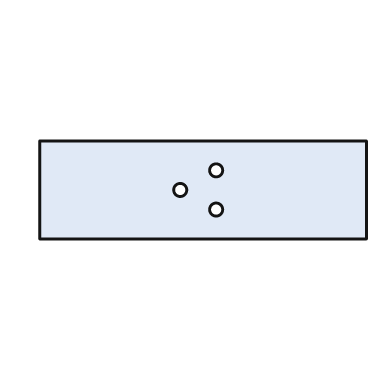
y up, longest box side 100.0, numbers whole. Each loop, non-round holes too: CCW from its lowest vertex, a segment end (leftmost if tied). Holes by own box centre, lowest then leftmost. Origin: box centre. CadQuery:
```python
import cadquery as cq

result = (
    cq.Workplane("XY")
    .moveTo(-50.0, -15.0)
    .lineTo(50.0, -15.0)
    .lineTo(50.0, 15.0)
    .lineTo(-50.0, 15.0)
    .close()
    .moveTo(4.0, -6.0)
    .circle(2.0)
    .moveTo(-7.0, 0.0)
    .circle(2.0)
    .moveTo(4.0, 6.0)
    .circle(2.0)
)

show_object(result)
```